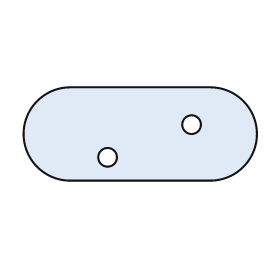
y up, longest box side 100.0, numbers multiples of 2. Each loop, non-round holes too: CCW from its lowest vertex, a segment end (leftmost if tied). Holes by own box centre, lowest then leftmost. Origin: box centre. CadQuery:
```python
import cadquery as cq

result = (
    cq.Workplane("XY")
    .moveTo(-30.0, -20.0)
    .lineTo(30.0, -20.0)
    .threePointArc((50.0, 0.0), (30.0, 20.0))
    .lineTo(-30.0, 20.0)
    .threePointArc((-50.0, 0.0), (-30.0, -20.0))
    .close()
    .moveTo(-14.0, -10.0)
    .circle(4.0)
    .moveTo(22.0, 4.0)
    .circle(4.0)
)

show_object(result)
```